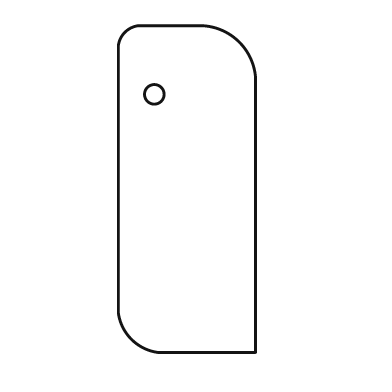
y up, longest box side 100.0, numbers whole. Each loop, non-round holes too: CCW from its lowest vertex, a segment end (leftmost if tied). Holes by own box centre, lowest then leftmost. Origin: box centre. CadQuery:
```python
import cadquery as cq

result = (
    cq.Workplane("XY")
    .moveTo(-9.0, -50.0)
    .lineTo(21.0, -50.0)
    .lineTo(21.0, 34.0)
    .threePointArc((16.0, 45.0), (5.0, 50.0))
    .lineTo(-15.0, 50.0)
    .threePointArc((-19.0, 48.0), (-21.0, 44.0))
    .lineTo(-21.0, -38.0)
    .threePointArc((-17.0, -46.0), (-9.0, -50.0))
    .close()
    .moveTo(-10.0, 29.0)
    .circle(3.0)
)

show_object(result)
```